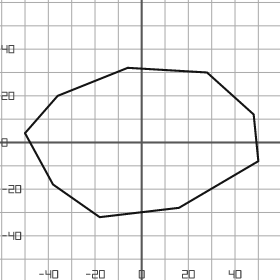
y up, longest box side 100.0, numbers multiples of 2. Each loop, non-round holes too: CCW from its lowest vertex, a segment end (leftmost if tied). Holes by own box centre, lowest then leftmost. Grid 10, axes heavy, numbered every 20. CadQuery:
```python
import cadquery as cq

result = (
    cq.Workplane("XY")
    .moveTo(-18.0, -32.0)
    .lineTo(16.0, -28.0)
    .lineTo(50.0, -8.0)
    .lineTo(48.0, 12.0)
    .lineTo(28.0, 30.0)
    .lineTo(-6.0, 32.0)
    .lineTo(-36.0, 20.0)
    .lineTo(-50.0, 4.0)
    .lineTo(-38.0, -18.0)
    .close()
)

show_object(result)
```